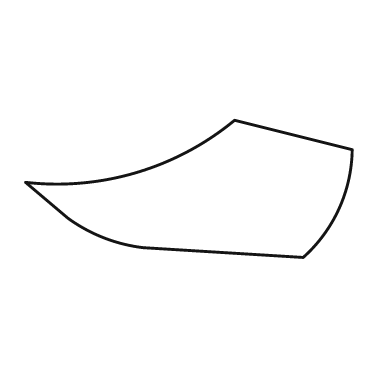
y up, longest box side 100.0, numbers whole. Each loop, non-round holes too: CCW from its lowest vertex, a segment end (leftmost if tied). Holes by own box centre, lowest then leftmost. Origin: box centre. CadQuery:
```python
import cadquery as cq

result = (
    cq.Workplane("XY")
    .moveTo(35.0, -21.0)
    .threePointArc((46.0, -6.0), (50.0, 12.0))
    .lineTo(14.0, 21.0)
    .threePointArc((-16.0, 5.0), (-50.0, 2.0))
    .lineTo(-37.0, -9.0)
    .threePointArc((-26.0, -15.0), (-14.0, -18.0))
    .close()
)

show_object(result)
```